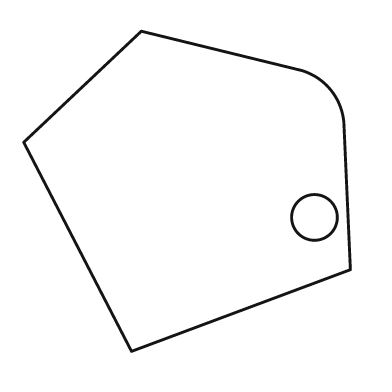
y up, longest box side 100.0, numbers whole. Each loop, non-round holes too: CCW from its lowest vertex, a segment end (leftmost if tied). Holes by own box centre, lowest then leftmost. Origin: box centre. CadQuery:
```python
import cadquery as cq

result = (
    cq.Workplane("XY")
    .moveTo(-17.0, -49.0)
    .lineTo(50.0, -24.0)
    .lineTo(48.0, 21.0)
    .threePointArc((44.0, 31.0), (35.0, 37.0))
    .lineTo(-14.0, 49.0)
    .lineTo(-50.0, 15.0)
    .close()
    .moveTo(39.0, -8.0)
    .circle(7.0)
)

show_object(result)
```